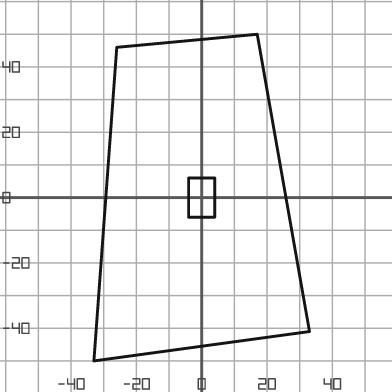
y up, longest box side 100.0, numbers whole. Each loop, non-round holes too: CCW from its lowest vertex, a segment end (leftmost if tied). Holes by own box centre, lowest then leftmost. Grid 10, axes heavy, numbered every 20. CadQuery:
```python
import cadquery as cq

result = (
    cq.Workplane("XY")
    .moveTo(-33.0, -50.0)
    .lineTo(33.0, -41.0)
    .lineTo(17.0, 50.0)
    .lineTo(-26.0, 46.0)
    .close()
    .moveTo(-4.0, -6.0)
    .lineTo(4.0, -6.0)
    .lineTo(4.0, 6.0)
    .lineTo(-4.0, 6.0)
    .close()
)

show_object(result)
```